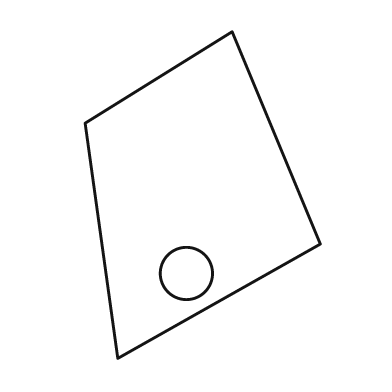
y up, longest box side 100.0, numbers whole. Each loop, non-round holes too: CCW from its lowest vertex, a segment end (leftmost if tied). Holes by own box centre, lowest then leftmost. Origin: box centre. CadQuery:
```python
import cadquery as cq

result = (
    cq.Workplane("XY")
    .moveTo(-26.0, -50.0)
    .lineTo(36.0, -15.0)
    .lineTo(9.0, 50.0)
    .lineTo(-36.0, 22.0)
    .close()
    .moveTo(-5.0, -24.0)
    .circle(8.0)
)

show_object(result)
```